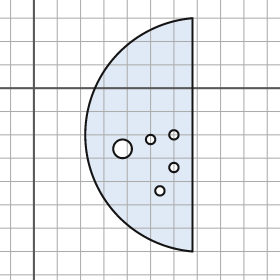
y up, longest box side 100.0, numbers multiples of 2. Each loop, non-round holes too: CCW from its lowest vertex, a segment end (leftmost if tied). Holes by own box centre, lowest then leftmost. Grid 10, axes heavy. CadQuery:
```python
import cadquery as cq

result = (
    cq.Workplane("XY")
    .moveTo(68.0, -70.0)
    .lineTo(68.0, 30.0)
    .threePointArc((22.0, -20.0), (68.0, -70.0))
    .close()
    .moveTo(54.0, -44.0)
    .circle(2.0)
    .moveTo(60.0, -34.0)
    .circle(2.0)
    .moveTo(38.0, -26.0)
    .circle(4.0)
    .moveTo(50.0, -22.0)
    .circle(2.0)
    .moveTo(60.0, -20.0)
    .circle(2.0)
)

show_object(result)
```